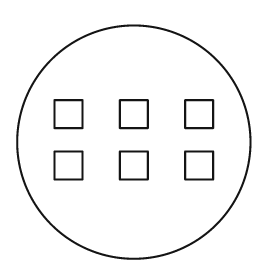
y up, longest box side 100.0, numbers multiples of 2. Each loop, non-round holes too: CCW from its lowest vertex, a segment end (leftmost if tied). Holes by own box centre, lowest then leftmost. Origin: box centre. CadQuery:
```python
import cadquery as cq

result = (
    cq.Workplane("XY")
    .moveTo(0.0, 0.0)
    .circle(50.0)
    .moveTo(-34.0, -16.0)
    .lineTo(-22.0, -16.0)
    .lineTo(-22.0, -4.0)
    .lineTo(-34.0, -4.0)
    .close()
    .moveTo(-6.0, -16.0)
    .lineTo(6.0, -16.0)
    .lineTo(6.0, -4.0)
    .lineTo(-6.0, -4.0)
    .close()
    .moveTo(22.0, -16.0)
    .lineTo(34.0, -16.0)
    .lineTo(34.0, -4.0)
    .lineTo(22.0, -4.0)
    .close()
    .moveTo(-34.0, 6.0)
    .lineTo(-22.0, 6.0)
    .lineTo(-22.0, 18.0)
    .lineTo(-34.0, 18.0)
    .close()
    .moveTo(-6.0, 6.0)
    .lineTo(6.0, 6.0)
    .lineTo(6.0, 18.0)
    .lineTo(-6.0, 18.0)
    .close()
    .moveTo(22.0, 6.0)
    .lineTo(34.0, 6.0)
    .lineTo(34.0, 18.0)
    .lineTo(22.0, 18.0)
    .close()
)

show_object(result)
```